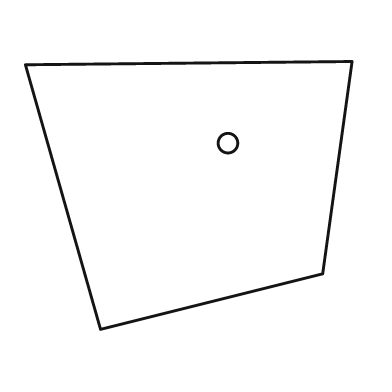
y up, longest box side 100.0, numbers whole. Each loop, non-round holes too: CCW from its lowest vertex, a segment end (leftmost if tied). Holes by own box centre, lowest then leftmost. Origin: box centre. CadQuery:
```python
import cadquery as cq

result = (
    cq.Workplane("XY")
    .moveTo(-27.0, -41.0)
    .lineTo(41.0, -24.0)
    .lineTo(50.0, 41.0)
    .lineTo(-50.0, 40.0)
    .close()
    .moveTo(12.0, 16.0)
    .circle(3.0)
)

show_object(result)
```